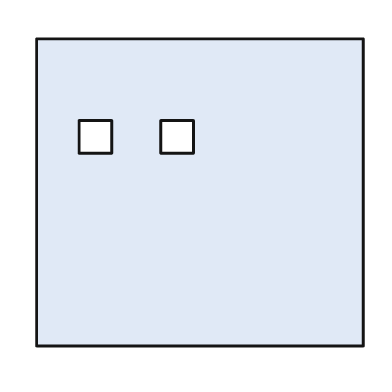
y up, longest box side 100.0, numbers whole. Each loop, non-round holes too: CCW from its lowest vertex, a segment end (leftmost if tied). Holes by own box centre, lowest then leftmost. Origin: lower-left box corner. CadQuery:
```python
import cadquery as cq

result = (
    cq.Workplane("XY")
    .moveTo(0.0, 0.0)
    .lineTo(100.0, 0.0)
    .lineTo(100.0, 94.0)
    .lineTo(0.0, 94.0)
    .close()
    .moveTo(13.0, 59.0)
    .lineTo(23.0, 59.0)
    .lineTo(23.0, 69.0)
    .lineTo(13.0, 69.0)
    .close()
    .moveTo(38.0, 59.0)
    .lineTo(48.0, 59.0)
    .lineTo(48.0, 69.0)
    .lineTo(38.0, 69.0)
    .close()
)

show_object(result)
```